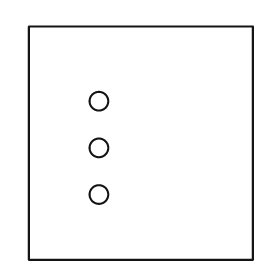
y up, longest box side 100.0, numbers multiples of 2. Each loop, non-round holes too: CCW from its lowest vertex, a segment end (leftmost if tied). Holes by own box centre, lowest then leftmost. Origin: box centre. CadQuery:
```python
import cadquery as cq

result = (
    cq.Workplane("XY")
    .moveTo(-48.0, -50.0)
    .lineTo(48.0, -50.0)
    .lineTo(48.0, 50.0)
    .lineTo(-48.0, 50.0)
    .close()
    .moveTo(-18.0, -22.0)
    .circle(4.0)
    .moveTo(-18.0, -2.0)
    .circle(4.0)
    .moveTo(-18.0, 18.0)
    .circle(4.0)
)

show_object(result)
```